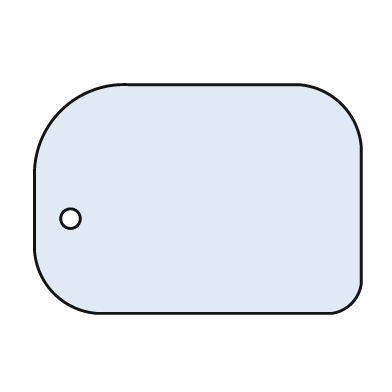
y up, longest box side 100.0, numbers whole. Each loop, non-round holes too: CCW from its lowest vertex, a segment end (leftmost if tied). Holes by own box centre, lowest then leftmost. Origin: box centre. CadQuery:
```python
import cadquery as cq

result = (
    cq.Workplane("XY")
    .moveTo(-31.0, -35.0)
    .lineTo(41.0, -35.0)
    .threePointArc((47.0, -32.0), (50.0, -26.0))
    .lineTo(50.0, 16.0)
    .threePointArc((44.0, 29.0), (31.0, 35.0))
    .lineTo(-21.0, 35.0)
    .threePointArc((-42.0, 27.0), (-50.0, 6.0))
    .lineTo(-50.0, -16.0)
    .threePointArc((-44.0, -29.0), (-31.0, -35.0))
    .close()
    .moveTo(-39.0, -6.0)
    .circle(3.0)
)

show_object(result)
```